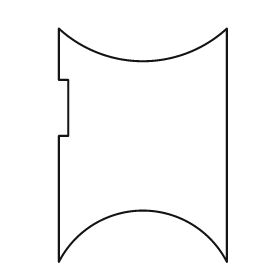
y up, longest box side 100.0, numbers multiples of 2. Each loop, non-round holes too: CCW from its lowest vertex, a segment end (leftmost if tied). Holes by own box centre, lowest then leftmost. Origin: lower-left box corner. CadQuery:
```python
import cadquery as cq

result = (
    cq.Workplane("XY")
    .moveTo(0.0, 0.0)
    .threePointArc((36.0, 22.0), (72.0, 0.0))
    .lineTo(72.0, 100.0)
    .threePointArc((36.0, 86.0), (0.0, 100.0))
    .lineTo(0.0, 78.0)
    .lineTo(4.0, 78.0)
    .lineTo(4.0, 54.0)
    .lineTo(0.0, 54.0)
    .close()
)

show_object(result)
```